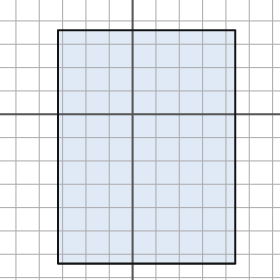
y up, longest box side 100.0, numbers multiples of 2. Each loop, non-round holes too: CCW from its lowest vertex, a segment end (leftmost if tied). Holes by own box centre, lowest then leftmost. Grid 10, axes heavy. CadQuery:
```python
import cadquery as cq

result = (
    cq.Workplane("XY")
    .moveTo(-32.0, -64.0)
    .lineTo(44.0, -64.0)
    .lineTo(44.0, 36.0)
    .lineTo(-32.0, 36.0)
    .close()
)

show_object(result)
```